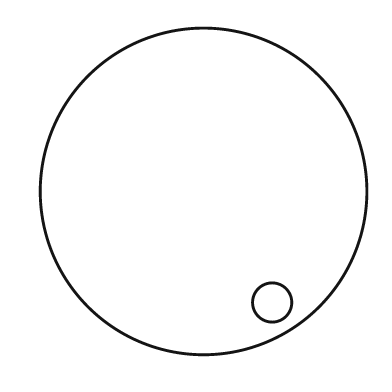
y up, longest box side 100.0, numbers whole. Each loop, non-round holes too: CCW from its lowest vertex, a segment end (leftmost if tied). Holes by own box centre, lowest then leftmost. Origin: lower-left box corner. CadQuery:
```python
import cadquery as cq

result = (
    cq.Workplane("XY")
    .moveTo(50.0, 50.0)
    .circle(50.0)
    .moveTo(71.0, 16.0)
    .circle(6.0)
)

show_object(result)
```